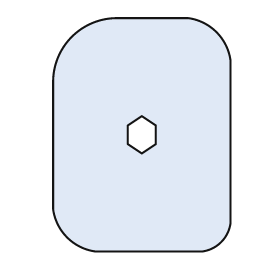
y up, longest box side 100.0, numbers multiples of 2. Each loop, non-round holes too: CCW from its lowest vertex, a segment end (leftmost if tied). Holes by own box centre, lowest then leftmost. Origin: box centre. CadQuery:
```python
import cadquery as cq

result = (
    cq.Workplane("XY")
    .moveTo(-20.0, -50.0)
    .lineTo(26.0, -50.0)
    .threePointArc((34.0, -46.0), (38.0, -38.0))
    .lineTo(38.0, 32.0)
    .threePointArc((32.0, 44.0), (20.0, 50.0))
    .lineTo(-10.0, 50.0)
    .threePointArc((-30.0, 42.0), (-38.0, 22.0))
    .lineTo(-38.0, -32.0)
    .threePointArc((-32.0, -44.0), (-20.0, -50.0))
    .close()
    .moveTo(0.0, -8.0)
    .lineTo(6.0, -4.0)
    .lineTo(6.0, 4.0)
    .lineTo(0.0, 8.0)
    .lineTo(-6.0, 4.0)
    .lineTo(-6.0, -4.0)
    .close()
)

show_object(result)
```